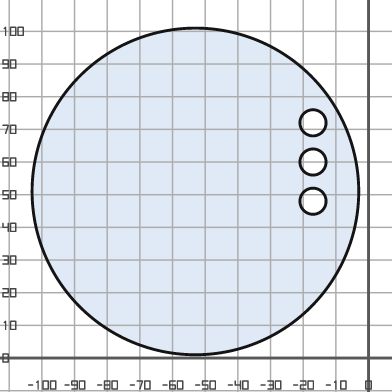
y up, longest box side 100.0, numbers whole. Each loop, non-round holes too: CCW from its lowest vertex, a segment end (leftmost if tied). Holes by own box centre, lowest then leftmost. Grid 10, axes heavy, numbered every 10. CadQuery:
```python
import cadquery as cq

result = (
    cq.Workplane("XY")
    .moveTo(-53.0, 51.0)
    .circle(50.0)
    .moveTo(-17.0, 48.0)
    .circle(4.0)
    .moveTo(-17.0, 60.0)
    .circle(4.0)
    .moveTo(-17.0, 72.0)
    .circle(4.0)
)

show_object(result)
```